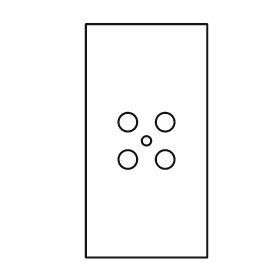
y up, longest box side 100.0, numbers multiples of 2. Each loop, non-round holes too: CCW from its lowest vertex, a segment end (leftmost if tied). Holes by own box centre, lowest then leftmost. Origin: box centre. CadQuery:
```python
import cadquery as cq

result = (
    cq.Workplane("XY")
    .moveTo(-26.0, -50.0)
    .lineTo(26.0, -50.0)
    .lineTo(26.0, 50.0)
    .lineTo(-26.0, 50.0)
    .close()
    .moveTo(-8.0, -8.0)
    .circle(4.0)
    .moveTo(8.0, -8.0)
    .circle(4.0)
    .moveTo(0.0, 0.0)
    .circle(2.0)
    .moveTo(-8.0, 8.0)
    .circle(4.0)
    .moveTo(8.0, 8.0)
    .circle(4.0)
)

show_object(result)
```